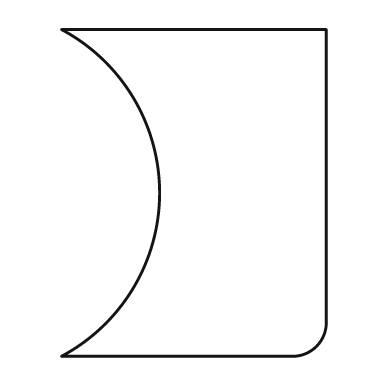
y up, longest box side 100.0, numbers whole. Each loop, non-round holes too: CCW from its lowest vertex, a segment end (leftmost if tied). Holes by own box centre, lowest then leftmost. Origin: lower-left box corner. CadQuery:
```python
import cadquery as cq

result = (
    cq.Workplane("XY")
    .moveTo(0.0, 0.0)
    .lineTo(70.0, 0.0)
    .threePointArc((78.0, 3.0), (81.0, 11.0))
    .lineTo(81.0, 100.0)
    .lineTo(0.0, 100.0)
    .threePointArc((30.0, 50.0), (0.0, 0.0))
    .close()
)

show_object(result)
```